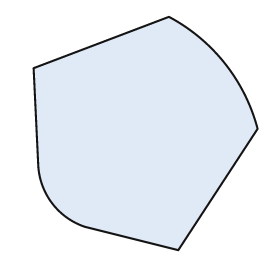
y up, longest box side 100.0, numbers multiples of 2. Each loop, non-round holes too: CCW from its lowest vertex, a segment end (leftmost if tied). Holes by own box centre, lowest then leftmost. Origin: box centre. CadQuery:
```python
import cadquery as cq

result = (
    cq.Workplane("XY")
    .moveTo(14.0, -50.0)
    .lineTo(48.0, 2.0)
    .threePointArc((34.0, 30.0), (10.0, 50.0))
    .lineTo(-48.0, 28.0)
    .lineTo(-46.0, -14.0)
    .threePointArc((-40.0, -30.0), (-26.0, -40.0))
    .close()
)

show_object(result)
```